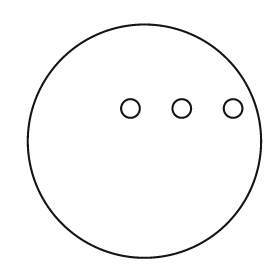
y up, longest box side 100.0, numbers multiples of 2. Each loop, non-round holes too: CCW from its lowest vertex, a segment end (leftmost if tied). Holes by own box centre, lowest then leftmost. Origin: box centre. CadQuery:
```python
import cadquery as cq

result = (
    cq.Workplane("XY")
    .moveTo(0.0, 0.0)
    .circle(50.0)
    .moveTo(-6.0, 14.0)
    .circle(4.0)
    .moveTo(16.0, 14.0)
    .circle(4.0)
    .moveTo(38.0, 14.0)
    .circle(4.0)
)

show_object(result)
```